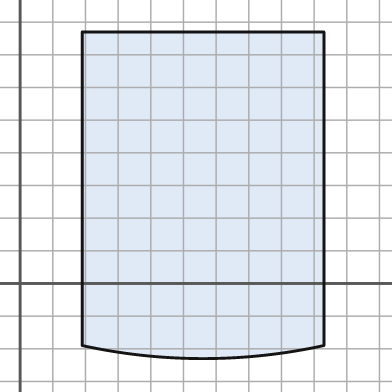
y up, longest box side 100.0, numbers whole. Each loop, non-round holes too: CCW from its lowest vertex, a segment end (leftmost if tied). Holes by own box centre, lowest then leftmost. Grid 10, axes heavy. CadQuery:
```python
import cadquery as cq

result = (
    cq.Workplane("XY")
    .moveTo(19.0, -19.0)
    .threePointArc((56.0, -23.0), (93.0, -19.0))
    .lineTo(93.0, 77.0)
    .lineTo(19.0, 77.0)
    .close()
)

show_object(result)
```